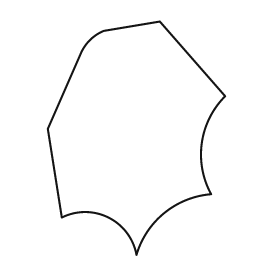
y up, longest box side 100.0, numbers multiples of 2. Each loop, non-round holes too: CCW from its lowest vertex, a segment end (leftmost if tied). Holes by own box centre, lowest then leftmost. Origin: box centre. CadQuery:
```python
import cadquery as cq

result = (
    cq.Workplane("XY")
    .moveTo(0.0, -50.0)
    .threePointArc((12.0, -32.0), (32.0, -24.0))
    .threePointArc((28.0, -2.0), (38.0, 18.0))
    .lineTo(10.0, 50.0)
    .lineTo(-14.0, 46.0)
    .threePointArc((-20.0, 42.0), (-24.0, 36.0))
    .lineTo(-38.0, 4.0)
    .lineTo(-32.0, -34.0)
    .threePointArc((-12.0, -34.0), (0.0, -50.0))
    .close()
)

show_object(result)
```